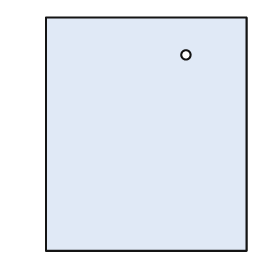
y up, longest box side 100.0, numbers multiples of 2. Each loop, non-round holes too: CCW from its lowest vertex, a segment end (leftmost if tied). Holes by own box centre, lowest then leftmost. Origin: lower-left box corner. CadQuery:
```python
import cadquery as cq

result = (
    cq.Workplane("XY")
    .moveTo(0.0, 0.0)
    .lineTo(86.0, 0.0)
    .lineTo(86.0, 100.0)
    .lineTo(0.0, 100.0)
    .close()
    .moveTo(60.0, 84.0)
    .circle(2.0)
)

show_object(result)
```